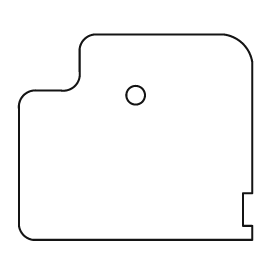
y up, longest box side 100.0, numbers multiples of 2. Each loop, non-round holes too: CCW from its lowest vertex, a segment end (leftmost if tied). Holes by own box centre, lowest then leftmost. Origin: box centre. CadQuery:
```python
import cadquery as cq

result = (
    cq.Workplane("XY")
    .moveTo(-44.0, -44.0)
    .lineTo(50.0, -44.0)
    .lineTo(50.0, -38.0)
    .lineTo(46.0, -38.0)
    .lineTo(46.0, -24.0)
    .lineTo(50.0, -24.0)
    .lineTo(50.0, 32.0)
    .threePointArc((46.0, 40.0), (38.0, 44.0))
    .lineTo(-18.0, 44.0)
    .threePointArc((-22.0, 42.0), (-24.0, 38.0))
    .lineTo(-24.0, 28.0)
    .threePointArc((-26.0, 22.0), (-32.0, 20.0))
    .lineTo(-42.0, 20.0)
    .threePointArc((-48.0, 18.0), (-50.0, 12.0))
    .lineTo(-50.0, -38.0)
    .threePointArc((-48.0, -42.0), (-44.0, -44.0))
    .close()
    .moveTo(0.0, 18.0)
    .circle(4.0)
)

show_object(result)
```